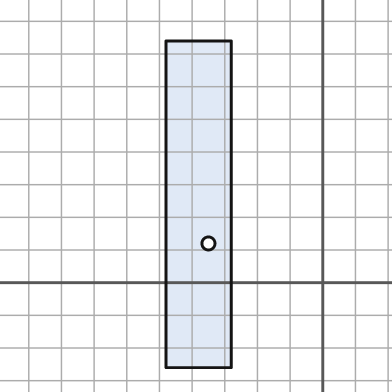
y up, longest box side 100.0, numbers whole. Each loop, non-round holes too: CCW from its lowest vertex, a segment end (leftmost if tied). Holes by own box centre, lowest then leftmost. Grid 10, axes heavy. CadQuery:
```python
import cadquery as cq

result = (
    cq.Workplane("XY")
    .moveTo(-48.0, -26.0)
    .lineTo(-28.0, -26.0)
    .lineTo(-28.0, 74.0)
    .lineTo(-48.0, 74.0)
    .close()
    .moveTo(-35.0, 12.0)
    .circle(2.0)
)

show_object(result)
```